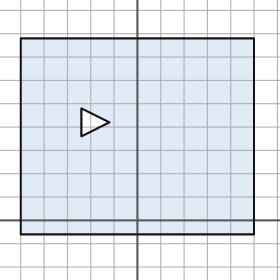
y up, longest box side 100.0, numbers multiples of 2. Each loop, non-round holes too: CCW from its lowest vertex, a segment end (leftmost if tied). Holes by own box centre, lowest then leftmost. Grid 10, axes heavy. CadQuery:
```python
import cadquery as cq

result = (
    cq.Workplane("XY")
    .moveTo(-50.0, -6.0)
    .lineTo(50.0, -6.0)
    .lineTo(50.0, 78.0)
    .lineTo(-50.0, 78.0)
    .close()
    .moveTo(-24.0, 36.0)
    .lineTo(-12.0, 42.0)
    .lineTo(-24.0, 48.0)
    .close()
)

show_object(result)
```